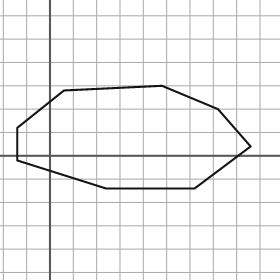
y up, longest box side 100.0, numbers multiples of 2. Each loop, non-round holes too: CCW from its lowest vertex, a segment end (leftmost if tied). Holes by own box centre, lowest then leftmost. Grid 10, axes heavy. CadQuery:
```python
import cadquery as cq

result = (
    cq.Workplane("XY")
    .moveTo(24.0, -14.0)
    .lineTo(62.0, -14.0)
    .lineTo(86.0, 4.0)
    .lineTo(72.0, 20.0)
    .lineTo(48.0, 30.0)
    .lineTo(6.0, 28.0)
    .lineTo(-14.0, 12.0)
    .lineTo(-14.0, -2.0)
    .close()
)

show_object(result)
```